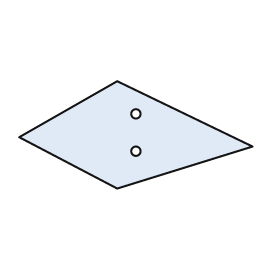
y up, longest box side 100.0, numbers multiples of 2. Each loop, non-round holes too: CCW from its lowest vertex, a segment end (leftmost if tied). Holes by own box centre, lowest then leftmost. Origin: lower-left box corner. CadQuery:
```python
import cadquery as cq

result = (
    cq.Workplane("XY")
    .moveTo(42.0, 0.0)
    .lineTo(100.0, 18.0)
    .lineTo(42.0, 46.0)
    .lineTo(0.0, 22.0)
    .close()
    .moveTo(50.0, 16.0)
    .circle(2.0)
    .moveTo(50.0, 32.0)
    .circle(2.0)
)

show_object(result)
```